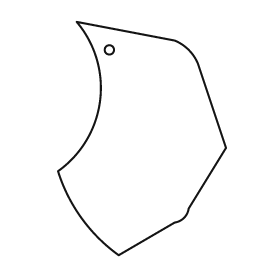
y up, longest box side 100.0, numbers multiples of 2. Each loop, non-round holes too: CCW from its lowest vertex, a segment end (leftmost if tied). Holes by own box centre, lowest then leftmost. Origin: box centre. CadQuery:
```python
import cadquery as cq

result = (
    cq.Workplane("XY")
    .moveTo(-10.0, -50.0)
    .lineTo(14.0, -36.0)
    .threePointArc((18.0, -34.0), (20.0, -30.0))
    .lineTo(36.0, -4.0)
    .lineTo(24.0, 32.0)
    .threePointArc((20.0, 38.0), (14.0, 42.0))
    .lineTo(-28.0, 50.0)
    .threePointArc((-18.0, 16.0), (-36.0, -14.0))
    .threePointArc((-26.0, -34.0), (-10.0, -50.0))
    .close()
    .moveTo(-14.0, 38.0)
    .circle(2.0)
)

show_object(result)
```